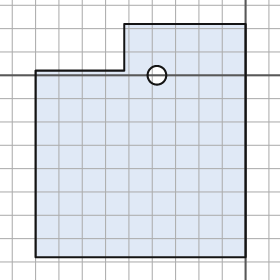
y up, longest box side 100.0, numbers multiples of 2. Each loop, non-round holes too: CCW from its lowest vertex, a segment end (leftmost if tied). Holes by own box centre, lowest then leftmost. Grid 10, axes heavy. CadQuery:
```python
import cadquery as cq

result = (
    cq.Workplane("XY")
    .moveTo(-90.0, -78.0)
    .lineTo(0.0, -78.0)
    .lineTo(0.0, 22.0)
    .lineTo(-52.0, 22.0)
    .lineTo(-52.0, 2.0)
    .lineTo(-90.0, 2.0)
    .close()
    .moveTo(-38.0, 0.0)
    .circle(4.0)
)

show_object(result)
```